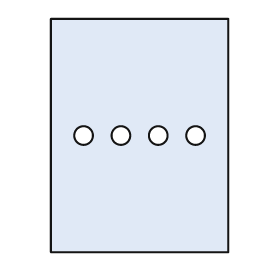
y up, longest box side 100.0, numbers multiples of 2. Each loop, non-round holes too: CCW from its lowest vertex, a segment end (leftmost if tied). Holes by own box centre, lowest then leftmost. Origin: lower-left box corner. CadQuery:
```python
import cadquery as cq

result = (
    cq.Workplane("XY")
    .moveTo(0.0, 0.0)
    .lineTo(76.0, 0.0)
    .lineTo(76.0, 100.0)
    .lineTo(0.0, 100.0)
    .close()
    .moveTo(14.0, 50.0)
    .circle(4.0)
    .moveTo(30.0, 50.0)
    .circle(4.0)
    .moveTo(46.0, 50.0)
    .circle(4.0)
    .moveTo(62.0, 50.0)
    .circle(4.0)
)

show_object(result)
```